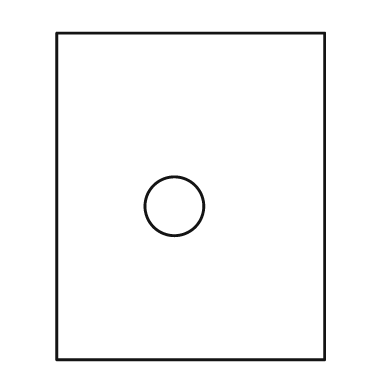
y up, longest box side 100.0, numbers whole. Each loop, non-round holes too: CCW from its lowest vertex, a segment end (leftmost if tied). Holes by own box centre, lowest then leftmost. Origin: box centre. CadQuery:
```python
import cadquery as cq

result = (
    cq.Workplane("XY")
    .moveTo(-41.0, -50.0)
    .lineTo(41.0, -50.0)
    .lineTo(41.0, 50.0)
    .lineTo(-41.0, 50.0)
    .close()
    .moveTo(-5.0, -3.0)
    .circle(9.0)
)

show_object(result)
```